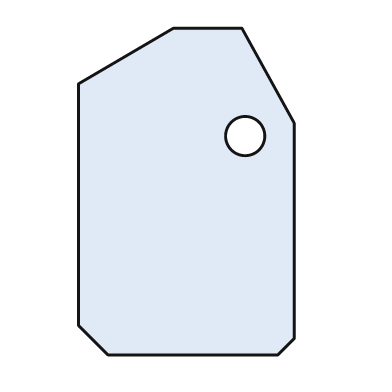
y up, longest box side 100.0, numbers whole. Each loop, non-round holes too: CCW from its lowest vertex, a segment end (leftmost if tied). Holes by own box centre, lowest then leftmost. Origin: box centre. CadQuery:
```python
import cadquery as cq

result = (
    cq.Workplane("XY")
    .moveTo(-24.0, -50.0)
    .lineTo(28.0, -50.0)
    .lineTo(33.0, -45.0)
    .lineTo(33.0, 21.0)
    .lineTo(17.0, 50.0)
    .lineTo(-4.0, 50.0)
    .lineTo(-33.0, 33.0)
    .lineTo(-33.0, -41.0)
    .close()
    .moveTo(18.0, 17.0)
    .circle(6.0)
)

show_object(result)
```